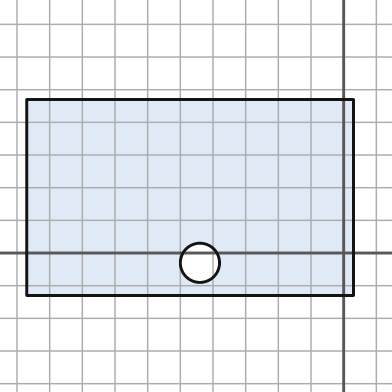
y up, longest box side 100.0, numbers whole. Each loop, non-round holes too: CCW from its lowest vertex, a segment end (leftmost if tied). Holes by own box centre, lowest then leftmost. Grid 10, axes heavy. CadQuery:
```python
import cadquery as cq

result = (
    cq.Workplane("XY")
    .moveTo(-97.0, -13.0)
    .lineTo(3.0, -13.0)
    .lineTo(3.0, 47.0)
    .lineTo(-97.0, 47.0)
    .close()
    .moveTo(-44.0, -3.0)
    .circle(6.0)
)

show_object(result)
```